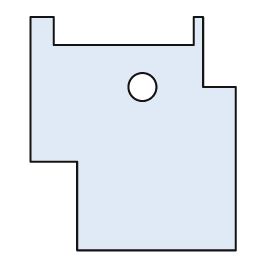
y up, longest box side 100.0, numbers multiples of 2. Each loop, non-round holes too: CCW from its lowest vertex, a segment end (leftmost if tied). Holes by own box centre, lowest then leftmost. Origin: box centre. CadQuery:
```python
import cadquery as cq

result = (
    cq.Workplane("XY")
    .moveTo(-24.0, -50.0)
    .lineTo(44.0, -50.0)
    .lineTo(44.0, 20.0)
    .lineTo(30.0, 20.0)
    .lineTo(30.0, 50.0)
    .lineTo(26.0, 50.0)
    .lineTo(26.0, 38.0)
    .lineTo(-34.0, 38.0)
    .lineTo(-34.0, 50.0)
    .lineTo(-44.0, 50.0)
    .lineTo(-44.0, -12.0)
    .lineTo(-24.0, -12.0)
    .close()
    .moveTo(4.0, 20.0)
    .circle(6.0)
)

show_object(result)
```